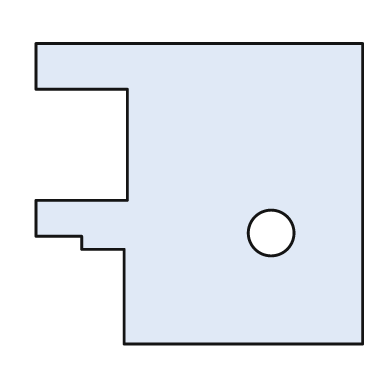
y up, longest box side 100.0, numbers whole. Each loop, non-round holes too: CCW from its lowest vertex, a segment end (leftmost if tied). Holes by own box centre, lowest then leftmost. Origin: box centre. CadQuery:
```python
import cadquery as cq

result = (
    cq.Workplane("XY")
    .moveTo(-23.0, -46.0)
    .lineTo(50.0, -46.0)
    .lineTo(50.0, 46.0)
    .lineTo(-50.0, 46.0)
    .lineTo(-50.0, 32.0)
    .lineTo(-22.0, 32.0)
    .lineTo(-22.0, -2.0)
    .lineTo(-50.0, -2.0)
    .lineTo(-50.0, -13.0)
    .lineTo(-36.0, -13.0)
    .lineTo(-36.0, -17.0)
    .lineTo(-23.0, -17.0)
    .close()
    .moveTo(22.0, -12.0)
    .circle(7.0)
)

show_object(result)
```